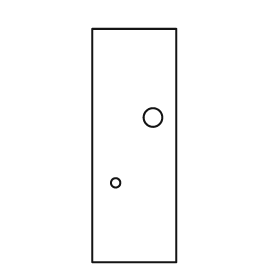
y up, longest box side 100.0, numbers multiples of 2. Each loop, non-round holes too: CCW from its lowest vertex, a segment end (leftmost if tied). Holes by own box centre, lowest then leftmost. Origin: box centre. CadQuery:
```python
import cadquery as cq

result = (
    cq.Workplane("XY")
    .moveTo(-18.0, -50.0)
    .lineTo(18.0, -50.0)
    .lineTo(18.0, 50.0)
    .lineTo(-18.0, 50.0)
    .close()
    .moveTo(-8.0, -16.0)
    .circle(2.0)
    .moveTo(8.0, 12.0)
    .circle(4.0)
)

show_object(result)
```